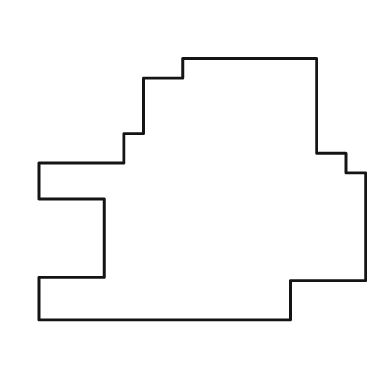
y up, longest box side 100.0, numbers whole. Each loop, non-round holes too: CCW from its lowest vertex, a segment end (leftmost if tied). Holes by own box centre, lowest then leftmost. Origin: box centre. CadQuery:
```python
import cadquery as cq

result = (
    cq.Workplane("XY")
    .moveTo(-50.0, -40.0)
    .lineTo(27.0, -40.0)
    .lineTo(27.0, -28.0)
    .lineTo(50.0, -28.0)
    .lineTo(50.0, 5.0)
    .lineTo(44.0, 5.0)
    .lineTo(44.0, 11.0)
    .lineTo(35.0, 11.0)
    .lineTo(35.0, 40.0)
    .lineTo(-6.0, 40.0)
    .lineTo(-6.0, 34.0)
    .lineTo(-18.0, 34.0)
    .lineTo(-18.0, 17.0)
    .lineTo(-24.0, 17.0)
    .lineTo(-24.0, 8.0)
    .lineTo(-50.0, 8.0)
    .lineTo(-50.0, -3.0)
    .lineTo(-30.0, -3.0)
    .lineTo(-30.0, -27.0)
    .lineTo(-50.0, -27.0)
    .close()
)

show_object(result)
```